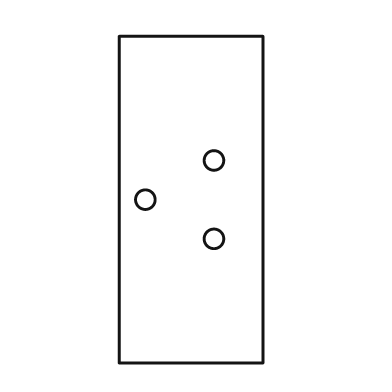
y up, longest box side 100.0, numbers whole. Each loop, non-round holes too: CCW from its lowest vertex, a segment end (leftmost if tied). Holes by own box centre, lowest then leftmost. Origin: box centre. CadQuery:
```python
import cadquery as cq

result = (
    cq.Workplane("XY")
    .moveTo(-22.0, -50.0)
    .lineTo(22.0, -50.0)
    .lineTo(22.0, 50.0)
    .lineTo(-22.0, 50.0)
    .close()
    .moveTo(7.0, -12.0)
    .circle(3.0)
    .moveTo(-14.0, 0.0)
    .circle(3.0)
    .moveTo(7.0, 12.0)
    .circle(3.0)
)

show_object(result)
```